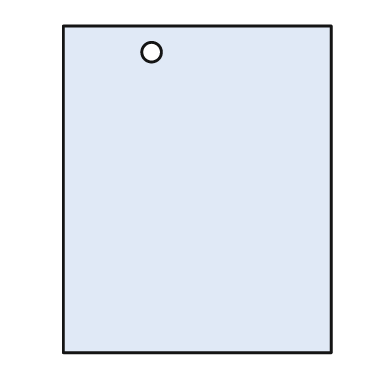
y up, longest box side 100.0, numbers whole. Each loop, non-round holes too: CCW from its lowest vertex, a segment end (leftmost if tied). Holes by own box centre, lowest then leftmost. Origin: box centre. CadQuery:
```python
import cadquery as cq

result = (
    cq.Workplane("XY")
    .moveTo(-41.0, -50.0)
    .lineTo(41.0, -50.0)
    .lineTo(41.0, 50.0)
    .lineTo(-41.0, 50.0)
    .close()
    .moveTo(-14.0, 42.0)
    .circle(3.0)
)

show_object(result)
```